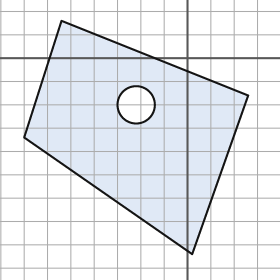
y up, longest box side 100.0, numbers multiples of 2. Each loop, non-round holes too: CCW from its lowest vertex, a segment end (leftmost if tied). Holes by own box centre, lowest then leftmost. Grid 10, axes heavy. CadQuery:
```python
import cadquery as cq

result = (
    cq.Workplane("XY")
    .moveTo(2.0, -84.0)
    .lineTo(26.0, -16.0)
    .lineTo(-54.0, 16.0)
    .lineTo(-70.0, -34.0)
    .close()
    .moveTo(-22.0, -20.0)
    .circle(8.0)
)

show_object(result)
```